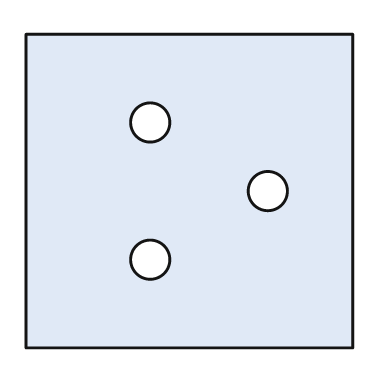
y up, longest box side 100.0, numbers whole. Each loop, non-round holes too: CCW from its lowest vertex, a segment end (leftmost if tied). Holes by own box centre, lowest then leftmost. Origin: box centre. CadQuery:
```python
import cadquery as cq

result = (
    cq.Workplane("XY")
    .moveTo(-50.0, -48.0)
    .lineTo(50.0, -48.0)
    .lineTo(50.0, 48.0)
    .lineTo(-50.0, 48.0)
    .close()
    .moveTo(-12.0, -21.0)
    .circle(6.0)
    .moveTo(24.0, 0.0)
    .circle(6.0)
    .moveTo(-12.0, 21.0)
    .circle(6.0)
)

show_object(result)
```